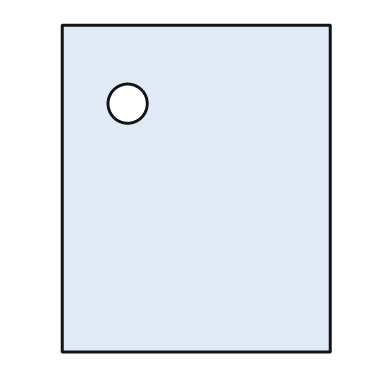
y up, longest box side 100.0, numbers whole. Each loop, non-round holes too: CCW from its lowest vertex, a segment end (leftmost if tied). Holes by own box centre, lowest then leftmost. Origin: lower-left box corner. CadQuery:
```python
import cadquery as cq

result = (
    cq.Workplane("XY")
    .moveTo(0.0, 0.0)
    .lineTo(82.0, 0.0)
    .lineTo(82.0, 100.0)
    .lineTo(0.0, 100.0)
    .close()
    .moveTo(20.0, 76.0)
    .circle(6.0)
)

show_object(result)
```